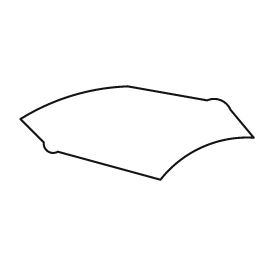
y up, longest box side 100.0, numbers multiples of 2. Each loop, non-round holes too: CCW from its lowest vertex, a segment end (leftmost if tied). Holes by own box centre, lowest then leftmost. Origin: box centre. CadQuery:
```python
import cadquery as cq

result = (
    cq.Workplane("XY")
    .moveTo(10.0, -20.0)
    .threePointArc((28.0, -6.0), (50.0, -2.0))
    .lineTo(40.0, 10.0)
    .threePointArc((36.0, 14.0), (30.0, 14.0))
    .lineTo(-4.0, 20.0)
    .threePointArc((-28.0, 16.0), (-50.0, 6.0))
    .lineTo(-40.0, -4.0)
    .threePointArc((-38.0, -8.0), (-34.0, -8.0))
    .close()
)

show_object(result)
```